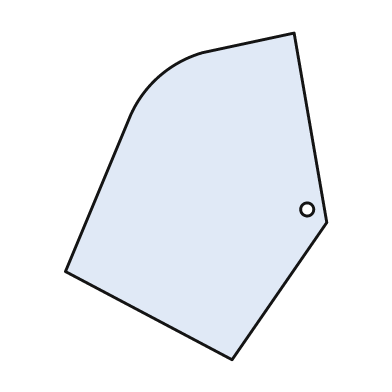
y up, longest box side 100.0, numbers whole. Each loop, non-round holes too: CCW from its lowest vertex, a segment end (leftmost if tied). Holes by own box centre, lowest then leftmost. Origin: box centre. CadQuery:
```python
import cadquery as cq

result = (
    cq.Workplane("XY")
    .moveTo(11.0, -50.0)
    .lineTo(40.0, -8.0)
    .lineTo(30.0, 50.0)
    .lineTo(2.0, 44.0)
    .threePointArc((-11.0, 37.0), (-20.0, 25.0))
    .lineTo(-40.0, -23.0)
    .close()
    .moveTo(34.0, -4.0)
    .circle(2.0)
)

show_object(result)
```